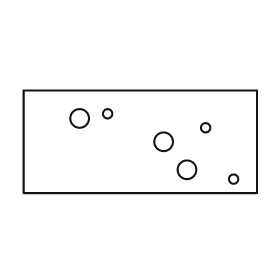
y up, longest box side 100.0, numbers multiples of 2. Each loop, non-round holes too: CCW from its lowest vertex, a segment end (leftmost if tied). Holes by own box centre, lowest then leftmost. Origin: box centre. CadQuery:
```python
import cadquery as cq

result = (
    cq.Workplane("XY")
    .moveTo(-50.0, -22.0)
    .lineTo(50.0, -22.0)
    .lineTo(50.0, 22.0)
    .lineTo(-50.0, 22.0)
    .close()
    .moveTo(40.0, -16.0)
    .circle(2.0)
    .moveTo(20.0, -12.0)
    .circle(4.0)
    .moveTo(10.0, 0.0)
    .circle(4.0)
    .moveTo(28.0, 6.0)
    .circle(2.0)
    .moveTo(-26.0, 10.0)
    .circle(4.0)
    .moveTo(-14.0, 12.0)
    .circle(2.0)
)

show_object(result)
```